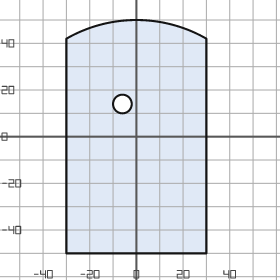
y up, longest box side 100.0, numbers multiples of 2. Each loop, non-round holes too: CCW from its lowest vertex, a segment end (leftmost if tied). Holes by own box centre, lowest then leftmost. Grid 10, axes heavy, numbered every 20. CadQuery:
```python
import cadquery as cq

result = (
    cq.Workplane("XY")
    .moveTo(-30.0, -50.0)
    .lineTo(30.0, -50.0)
    .lineTo(30.0, 42.0)
    .threePointArc((0.0, 50.0), (-30.0, 42.0))
    .close()
    .moveTo(-6.0, 14.0)
    .circle(4.0)
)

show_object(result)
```